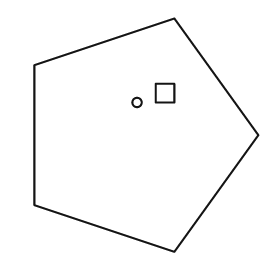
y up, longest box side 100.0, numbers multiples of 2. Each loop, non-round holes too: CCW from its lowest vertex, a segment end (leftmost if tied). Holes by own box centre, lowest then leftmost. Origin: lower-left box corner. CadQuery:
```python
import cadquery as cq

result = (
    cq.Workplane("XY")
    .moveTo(60.0, 0.0)
    .lineTo(96.0, 50.0)
    .lineTo(60.0, 100.0)
    .lineTo(0.0, 80.0)
    .lineTo(0.0, 20.0)
    .close()
    .moveTo(44.0, 64.0)
    .circle(2.0)
    .moveTo(52.0, 64.0)
    .lineTo(60.0, 64.0)
    .lineTo(60.0, 72.0)
    .lineTo(52.0, 72.0)
    .close()
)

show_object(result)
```